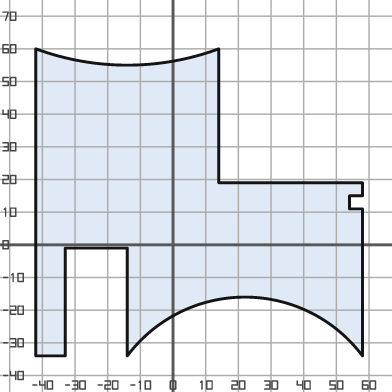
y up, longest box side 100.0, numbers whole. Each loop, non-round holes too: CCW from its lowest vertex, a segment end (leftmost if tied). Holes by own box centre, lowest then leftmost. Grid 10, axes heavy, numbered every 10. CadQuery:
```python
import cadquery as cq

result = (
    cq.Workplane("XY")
    .moveTo(-42.0, -34.0)
    .lineTo(-33.0, -34.0)
    .lineTo(-33.0, -1.0)
    .lineTo(-14.0, -1.0)
    .lineTo(-14.0, -34.0)
    .threePointArc((22.0, -16.0), (58.0, -34.0))
    .lineTo(58.0, 11.0)
    .lineTo(54.0, 11.0)
    .lineTo(54.0, 15.0)
    .lineTo(58.0, 15.0)
    .lineTo(58.0, 19.0)
    .lineTo(14.0, 19.0)
    .lineTo(14.0, 60.0)
    .threePointArc((-14.0, 55.0), (-42.0, 60.0))
    .close()
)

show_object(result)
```